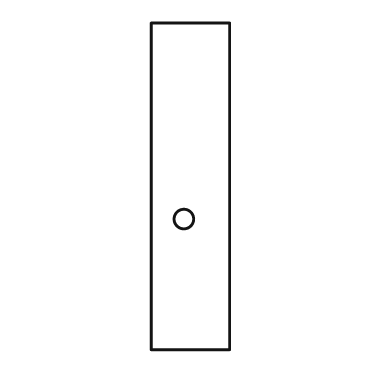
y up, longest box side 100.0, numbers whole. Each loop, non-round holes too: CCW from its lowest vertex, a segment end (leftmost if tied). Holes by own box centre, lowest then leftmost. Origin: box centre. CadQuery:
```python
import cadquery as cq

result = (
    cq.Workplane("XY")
    .moveTo(-12.0, -50.0)
    .lineTo(12.0, -50.0)
    .lineTo(12.0, 50.0)
    .lineTo(-12.0, 50.0)
    .close()
    .moveTo(-2.0, -10.0)
    .circle(3.0)
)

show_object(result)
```